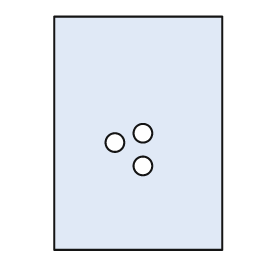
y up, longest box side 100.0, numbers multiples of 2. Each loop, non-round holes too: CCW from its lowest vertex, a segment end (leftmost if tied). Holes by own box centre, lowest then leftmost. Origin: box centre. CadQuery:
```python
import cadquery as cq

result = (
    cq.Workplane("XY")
    .moveTo(-36.0, -50.0)
    .lineTo(36.0, -50.0)
    .lineTo(36.0, 50.0)
    .lineTo(-36.0, 50.0)
    .close()
    .moveTo(2.0, -14.0)
    .circle(4.0)
    .moveTo(-10.0, -4.0)
    .circle(4.0)
    .moveTo(2.0, 0.0)
    .circle(4.0)
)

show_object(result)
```